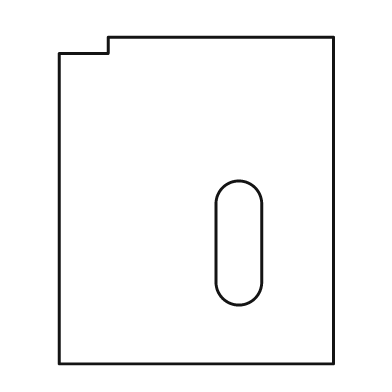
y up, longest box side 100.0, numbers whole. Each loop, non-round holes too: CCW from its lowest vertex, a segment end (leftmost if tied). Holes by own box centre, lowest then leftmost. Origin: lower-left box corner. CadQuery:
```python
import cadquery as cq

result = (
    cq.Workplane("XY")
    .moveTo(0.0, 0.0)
    .lineTo(84.0, 0.0)
    .lineTo(84.0, 100.0)
    .lineTo(15.0, 100.0)
    .lineTo(15.0, 95.0)
    .lineTo(0.0, 95.0)
    .close()
    .moveTo(48.0, 25.0)
    .threePointArc((55.0, 18.0), (62.0, 25.0))
    .lineTo(62.0, 49.0)
    .threePointArc((55.0, 56.0), (48.0, 49.0))
    .close()
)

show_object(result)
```